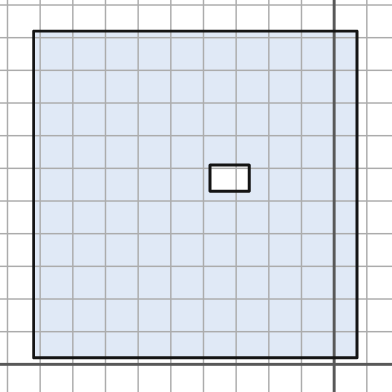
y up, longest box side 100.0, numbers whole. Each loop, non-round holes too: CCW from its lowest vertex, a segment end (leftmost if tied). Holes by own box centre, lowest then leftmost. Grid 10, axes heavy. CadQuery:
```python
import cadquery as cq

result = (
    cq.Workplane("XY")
    .moveTo(-92.0, 2.0)
    .lineTo(7.0, 2.0)
    .lineTo(7.0, 102.0)
    .lineTo(-92.0, 102.0)
    .close()
    .moveTo(-38.0, 53.0)
    .lineTo(-26.0, 53.0)
    .lineTo(-26.0, 61.0)
    .lineTo(-38.0, 61.0)
    .close()
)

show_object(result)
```